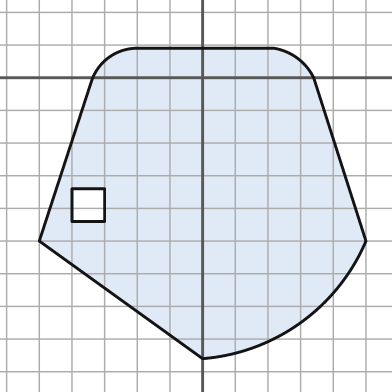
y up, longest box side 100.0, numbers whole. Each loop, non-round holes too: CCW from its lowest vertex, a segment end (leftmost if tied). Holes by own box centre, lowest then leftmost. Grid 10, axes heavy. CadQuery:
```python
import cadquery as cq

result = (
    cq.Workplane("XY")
    .moveTo(0.0, -86.0)
    .threePointArc((30.0, -75.0), (50.0, -50.0))
    .lineTo(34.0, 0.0)
    .threePointArc((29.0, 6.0), (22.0, 9.0))
    .lineTo(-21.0, 9.0)
    .threePointArc((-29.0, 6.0), (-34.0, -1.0))
    .lineTo(-50.0, -50.0)
    .close()
    .moveTo(-40.0, -44.0)
    .lineTo(-30.0, -44.0)
    .lineTo(-30.0, -34.0)
    .lineTo(-40.0, -34.0)
    .close()
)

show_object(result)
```